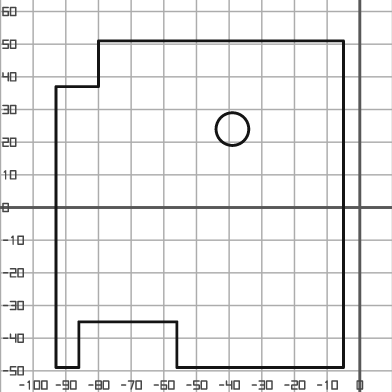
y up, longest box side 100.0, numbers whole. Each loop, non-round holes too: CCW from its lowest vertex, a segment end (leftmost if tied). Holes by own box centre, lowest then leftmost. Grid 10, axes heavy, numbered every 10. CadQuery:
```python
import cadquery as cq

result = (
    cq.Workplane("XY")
    .moveTo(-93.0, -49.0)
    .lineTo(-86.0, -49.0)
    .lineTo(-86.0, -35.0)
    .lineTo(-56.0, -35.0)
    .lineTo(-56.0, -49.0)
    .lineTo(-5.0, -49.0)
    .lineTo(-5.0, 51.0)
    .lineTo(-80.0, 51.0)
    .lineTo(-80.0, 37.0)
    .lineTo(-93.0, 37.0)
    .close()
    .moveTo(-39.0, 24.0)
    .circle(5.0)
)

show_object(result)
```